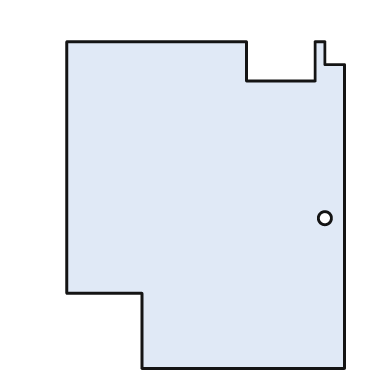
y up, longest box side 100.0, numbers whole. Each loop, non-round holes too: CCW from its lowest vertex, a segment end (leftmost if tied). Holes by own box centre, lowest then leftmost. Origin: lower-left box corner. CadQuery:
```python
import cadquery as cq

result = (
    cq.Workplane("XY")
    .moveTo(23.0, 0.0)
    .lineTo(85.0, 0.0)
    .lineTo(85.0, 93.0)
    .lineTo(79.0, 93.0)
    .lineTo(79.0, 100.0)
    .lineTo(76.0, 100.0)
    .lineTo(76.0, 88.0)
    .lineTo(55.0, 88.0)
    .lineTo(55.0, 100.0)
    .lineTo(0.0, 100.0)
    .lineTo(0.0, 23.0)
    .lineTo(23.0, 23.0)
    .close()
    .moveTo(79.0, 46.0)
    .circle(2.0)
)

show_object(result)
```